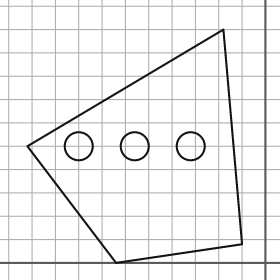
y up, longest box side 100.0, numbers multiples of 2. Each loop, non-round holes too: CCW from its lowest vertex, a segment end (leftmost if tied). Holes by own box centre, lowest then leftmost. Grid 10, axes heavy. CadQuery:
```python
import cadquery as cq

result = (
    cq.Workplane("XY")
    .moveTo(-64.0, 0.0)
    .lineTo(-10.0, 8.0)
    .lineTo(-18.0, 100.0)
    .lineTo(-102.0, 50.0)
    .close()
    .moveTo(-80.0, 50.0)
    .circle(6.0)
    .moveTo(-56.0, 50.0)
    .circle(6.0)
    .moveTo(-32.0, 50.0)
    .circle(6.0)
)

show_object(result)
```